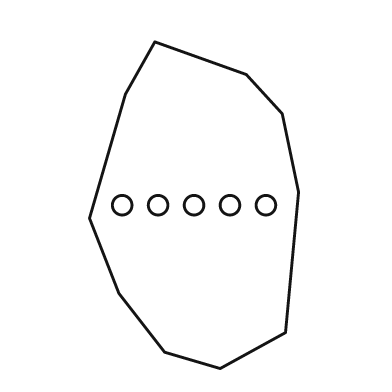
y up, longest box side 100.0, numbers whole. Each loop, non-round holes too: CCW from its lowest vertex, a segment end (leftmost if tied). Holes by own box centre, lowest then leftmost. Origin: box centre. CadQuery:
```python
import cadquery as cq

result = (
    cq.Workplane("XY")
    .moveTo(8.0, -50.0)
    .lineTo(28.0, -39.0)
    .lineTo(32.0, 4.0)
    .lineTo(27.0, 28.0)
    .lineTo(16.0, 40.0)
    .lineTo(-12.0, 50.0)
    .lineTo(-21.0, 34.0)
    .lineTo(-32.0, -4.0)
    .lineTo(-23.0, -27.0)
    .lineTo(-9.0, -45.0)
    .close()
    .moveTo(-22.0, 0.0)
    .circle(3.0)
    .moveTo(-11.0, 0.0)
    .circle(3.0)
    .moveTo(0.0, 0.0)
    .circle(3.0)
    .moveTo(11.0, 0.0)
    .circle(3.0)
    .moveTo(22.0, 0.0)
    .circle(3.0)
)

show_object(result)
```